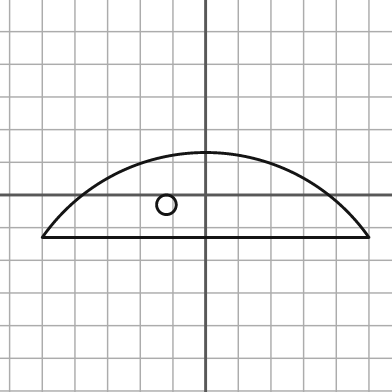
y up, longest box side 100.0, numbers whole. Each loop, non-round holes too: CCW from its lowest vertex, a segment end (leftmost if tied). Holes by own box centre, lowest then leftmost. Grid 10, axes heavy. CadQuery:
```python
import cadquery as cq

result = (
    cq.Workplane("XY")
    .moveTo(-50.0, -13.0)
    .lineTo(50.0, -13.0)
    .threePointArc((0.0, 13.0), (-50.0, -13.0))
    .close()
    .moveTo(-12.0, -3.0)
    .circle(3.0)
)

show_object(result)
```